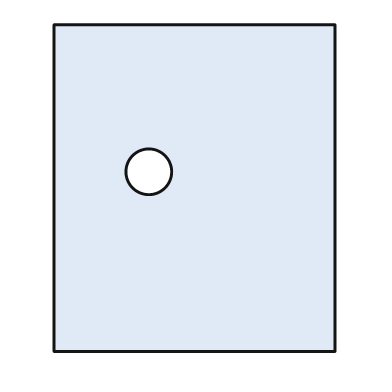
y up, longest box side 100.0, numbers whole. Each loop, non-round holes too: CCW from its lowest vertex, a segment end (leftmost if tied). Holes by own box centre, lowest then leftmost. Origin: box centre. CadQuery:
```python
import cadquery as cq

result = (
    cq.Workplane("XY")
    .moveTo(-43.0, -50.0)
    .lineTo(43.0, -50.0)
    .lineTo(43.0, 50.0)
    .lineTo(-43.0, 50.0)
    .close()
    .moveTo(-14.0, 5.0)
    .circle(7.0)
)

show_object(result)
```